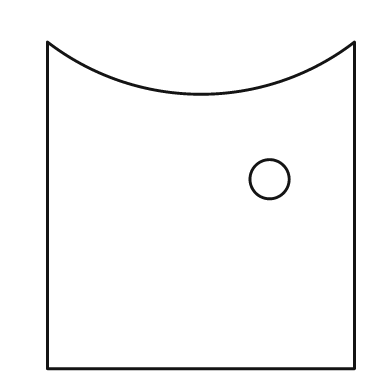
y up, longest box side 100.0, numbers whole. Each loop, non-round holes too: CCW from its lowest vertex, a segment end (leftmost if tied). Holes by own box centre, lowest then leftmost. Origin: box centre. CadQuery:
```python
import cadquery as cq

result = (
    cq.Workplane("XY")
    .moveTo(-47.0, -50.0)
    .lineTo(47.0, -50.0)
    .lineTo(47.0, 50.0)
    .threePointArc((0.0, 34.0), (-47.0, 50.0))
    .close()
    .moveTo(21.0, 8.0)
    .circle(6.0)
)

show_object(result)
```